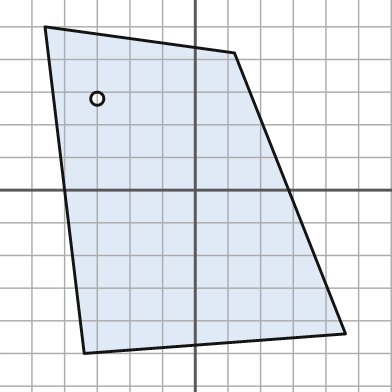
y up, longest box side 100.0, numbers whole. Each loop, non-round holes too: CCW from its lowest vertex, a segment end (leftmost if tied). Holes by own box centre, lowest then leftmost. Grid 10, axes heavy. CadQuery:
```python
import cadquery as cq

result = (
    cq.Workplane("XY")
    .moveTo(-34.0, -50.0)
    .lineTo(46.0, -44.0)
    .lineTo(12.0, 42.0)
    .lineTo(-46.0, 50.0)
    .close()
    .moveTo(-30.0, 28.0)
    .circle(2.0)
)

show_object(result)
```